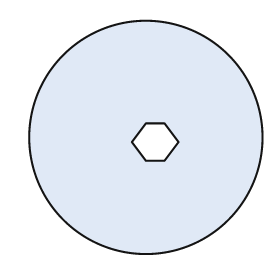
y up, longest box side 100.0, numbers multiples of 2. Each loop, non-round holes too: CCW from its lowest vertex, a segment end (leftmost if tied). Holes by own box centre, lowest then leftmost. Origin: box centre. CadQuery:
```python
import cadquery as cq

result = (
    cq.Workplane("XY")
    .moveTo(0.0, 0.0)
    .circle(50.0)
    .moveTo(0.0, -10.0)
    .lineTo(8.0, -10.0)
    .lineTo(14.0, -2.0)
    .lineTo(8.0, 6.0)
    .lineTo(0.0, 6.0)
    .lineTo(-6.0, -2.0)
    .close()
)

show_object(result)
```